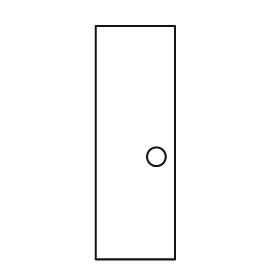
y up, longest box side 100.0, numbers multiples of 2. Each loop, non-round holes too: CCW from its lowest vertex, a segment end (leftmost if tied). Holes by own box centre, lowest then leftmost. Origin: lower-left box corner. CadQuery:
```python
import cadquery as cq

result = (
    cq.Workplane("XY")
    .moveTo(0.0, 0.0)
    .lineTo(34.0, 0.0)
    .lineTo(34.0, 100.0)
    .lineTo(0.0, 100.0)
    .close()
    .moveTo(26.0, 44.0)
    .circle(4.0)
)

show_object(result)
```